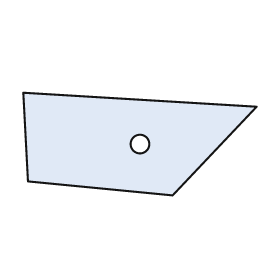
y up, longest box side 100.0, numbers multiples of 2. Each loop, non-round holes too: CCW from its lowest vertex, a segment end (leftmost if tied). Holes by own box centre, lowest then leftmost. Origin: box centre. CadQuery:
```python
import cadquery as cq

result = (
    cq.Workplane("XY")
    .moveTo(14.0, -22.0)
    .lineTo(50.0, 16.0)
    .lineTo(-50.0, 22.0)
    .lineTo(-48.0, -16.0)
    .close()
    .moveTo(0.0, 0.0)
    .circle(4.0)
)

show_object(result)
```